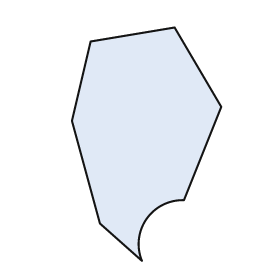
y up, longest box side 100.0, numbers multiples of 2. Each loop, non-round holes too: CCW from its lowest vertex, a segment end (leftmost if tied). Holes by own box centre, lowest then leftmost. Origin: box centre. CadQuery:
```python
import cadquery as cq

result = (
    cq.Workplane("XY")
    .moveTo(-2.0, -50.0)
    .threePointArc((0.0, -32.0), (16.0, -24.0))
    .lineTo(32.0, 16.0)
    .lineTo(12.0, 50.0)
    .lineTo(-24.0, 44.0)
    .lineTo(-32.0, 10.0)
    .lineTo(-20.0, -34.0)
    .close()
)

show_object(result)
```